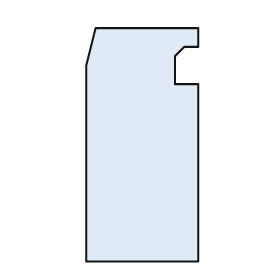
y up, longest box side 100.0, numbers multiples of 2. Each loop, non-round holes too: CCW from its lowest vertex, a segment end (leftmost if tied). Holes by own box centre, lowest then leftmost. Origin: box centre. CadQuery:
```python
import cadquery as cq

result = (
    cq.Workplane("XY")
    .moveTo(-24.0, -50.0)
    .lineTo(24.0, -50.0)
    .lineTo(24.0, 26.0)
    .lineTo(14.0, 26.0)
    .lineTo(14.0, 38.0)
    .lineTo(18.0, 42.0)
    .lineTo(24.0, 42.0)
    .lineTo(24.0, 50.0)
    .lineTo(-20.0, 50.0)
    .lineTo(-24.0, 34.0)
    .close()
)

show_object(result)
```